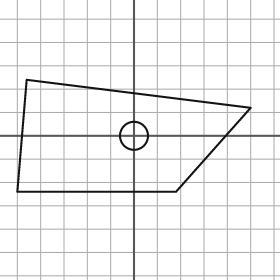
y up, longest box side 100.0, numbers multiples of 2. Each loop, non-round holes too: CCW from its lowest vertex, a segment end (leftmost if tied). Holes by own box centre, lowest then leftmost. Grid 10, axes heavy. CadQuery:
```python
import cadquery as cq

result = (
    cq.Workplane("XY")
    .moveTo(-50.0, -24.0)
    .lineTo(18.0, -24.0)
    .lineTo(50.0, 12.0)
    .lineTo(-46.0, 24.0)
    .close()
    .moveTo(0.0, 0.0)
    .circle(6.0)
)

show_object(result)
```